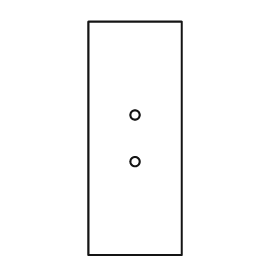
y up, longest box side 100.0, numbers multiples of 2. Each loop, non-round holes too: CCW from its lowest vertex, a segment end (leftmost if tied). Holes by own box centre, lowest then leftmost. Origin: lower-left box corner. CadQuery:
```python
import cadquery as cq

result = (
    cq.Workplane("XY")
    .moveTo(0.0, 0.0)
    .lineTo(40.0, 0.0)
    .lineTo(40.0, 100.0)
    .lineTo(0.0, 100.0)
    .close()
    .moveTo(20.0, 40.0)
    .circle(2.0)
    .moveTo(20.0, 60.0)
    .circle(2.0)
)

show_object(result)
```